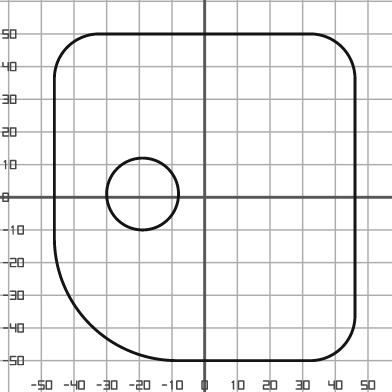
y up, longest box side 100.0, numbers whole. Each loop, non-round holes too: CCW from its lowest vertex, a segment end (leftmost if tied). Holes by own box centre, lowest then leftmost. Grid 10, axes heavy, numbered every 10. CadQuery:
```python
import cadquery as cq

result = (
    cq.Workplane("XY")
    .moveTo(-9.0, -50.0)
    .lineTo(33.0, -50.0)
    .threePointArc((42.0, -46.0), (46.0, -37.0))
    .lineTo(46.0, 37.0)
    .threePointArc((42.0, 46.0), (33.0, 50.0))
    .lineTo(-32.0, 50.0)
    .threePointArc((-42.0, 46.0), (-46.0, 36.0))
    .lineTo(-46.0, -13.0)
    .threePointArc((-35.0, -39.0), (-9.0, -50.0))
    .close()
    .moveTo(-19.0, 1.0)
    .circle(11.0)
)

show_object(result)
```